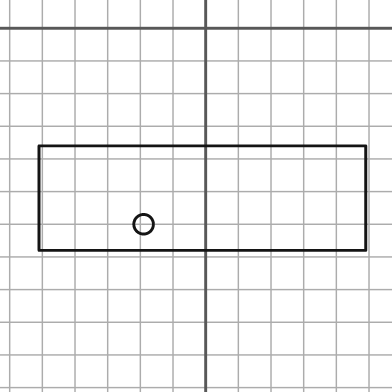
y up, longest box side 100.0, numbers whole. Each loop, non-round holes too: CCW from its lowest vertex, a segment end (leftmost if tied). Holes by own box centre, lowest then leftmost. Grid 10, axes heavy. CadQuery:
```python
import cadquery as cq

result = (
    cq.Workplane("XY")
    .moveTo(-51.0, -68.0)
    .lineTo(49.0, -68.0)
    .lineTo(49.0, -36.0)
    .lineTo(-51.0, -36.0)
    .close()
    .moveTo(-19.0, -60.0)
    .circle(3.0)
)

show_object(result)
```